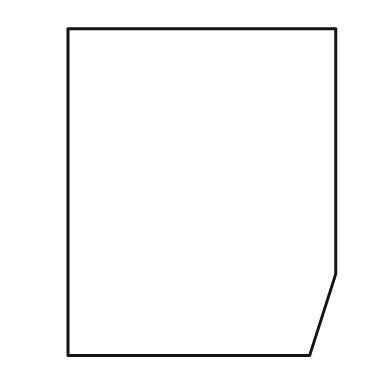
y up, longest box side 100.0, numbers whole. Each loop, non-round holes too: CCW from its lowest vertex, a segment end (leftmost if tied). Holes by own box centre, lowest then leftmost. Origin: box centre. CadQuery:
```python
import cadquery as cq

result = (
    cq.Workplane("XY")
    .moveTo(-41.0, -50.0)
    .lineTo(33.0, -50.0)
    .lineTo(41.0, -25.0)
    .lineTo(41.0, 50.0)
    .lineTo(-41.0, 50.0)
    .close()
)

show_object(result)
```